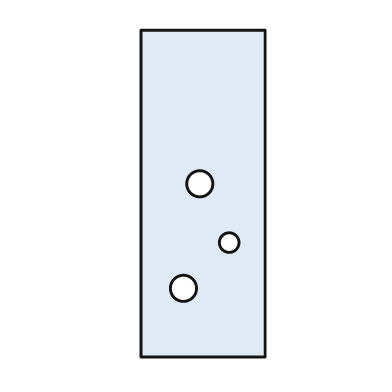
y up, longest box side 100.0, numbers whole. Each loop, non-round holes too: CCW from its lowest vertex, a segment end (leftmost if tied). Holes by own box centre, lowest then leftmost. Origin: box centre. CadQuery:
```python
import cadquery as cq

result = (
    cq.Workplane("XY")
    .moveTo(-19.0, -50.0)
    .lineTo(19.0, -50.0)
    .lineTo(19.0, 50.0)
    .lineTo(-19.0, 50.0)
    .close()
    .moveTo(-6.0, -29.0)
    .circle(4.0)
    .moveTo(8.0, -15.0)
    .circle(3.0)
    .moveTo(-1.0, 3.0)
    .circle(4.0)
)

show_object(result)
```